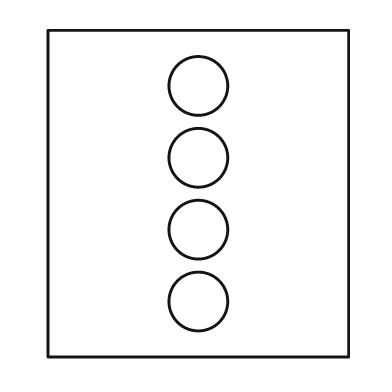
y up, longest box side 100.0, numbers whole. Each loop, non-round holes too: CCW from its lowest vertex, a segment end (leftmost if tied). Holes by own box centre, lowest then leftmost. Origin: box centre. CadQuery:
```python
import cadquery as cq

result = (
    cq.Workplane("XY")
    .moveTo(-46.0, -50.0)
    .lineTo(46.0, -50.0)
    .lineTo(46.0, 50.0)
    .lineTo(-46.0, 50.0)
    .close()
    .moveTo(0.0, -33.0)
    .circle(9.0)
    .moveTo(0.0, -11.0)
    .circle(9.0)
    .moveTo(0.0, 11.0)
    .circle(9.0)
    .moveTo(0.0, 33.0)
    .circle(9.0)
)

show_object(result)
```